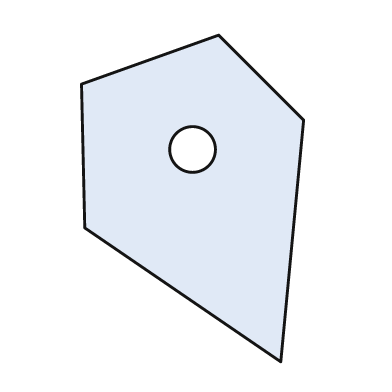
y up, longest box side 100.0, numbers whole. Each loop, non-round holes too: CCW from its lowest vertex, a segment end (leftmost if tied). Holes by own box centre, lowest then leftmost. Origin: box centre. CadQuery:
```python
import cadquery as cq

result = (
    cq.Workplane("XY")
    .moveTo(27.0, -50.0)
    .lineTo(34.0, 24.0)
    .lineTo(8.0, 50.0)
    .lineTo(-34.0, 35.0)
    .lineTo(-33.0, -9.0)
    .close()
    .moveTo(0.0, 15.0)
    .circle(7.0)
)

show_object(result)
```